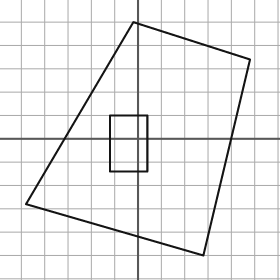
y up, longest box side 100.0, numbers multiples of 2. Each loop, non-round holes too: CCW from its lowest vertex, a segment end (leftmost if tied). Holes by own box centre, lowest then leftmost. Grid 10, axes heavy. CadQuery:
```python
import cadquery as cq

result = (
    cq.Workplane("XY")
    .moveTo(28.0, -50.0)
    .lineTo(48.0, 34.0)
    .lineTo(-2.0, 50.0)
    .lineTo(-48.0, -28.0)
    .close()
    .moveTo(-12.0, -14.0)
    .lineTo(4.0, -14.0)
    .lineTo(4.0, 10.0)
    .lineTo(-12.0, 10.0)
    .close()
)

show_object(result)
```